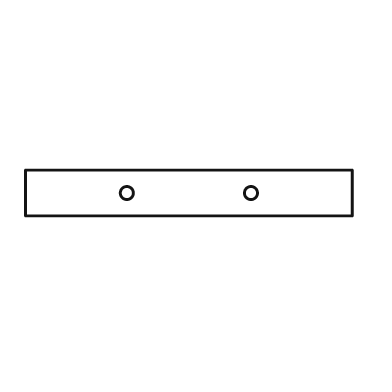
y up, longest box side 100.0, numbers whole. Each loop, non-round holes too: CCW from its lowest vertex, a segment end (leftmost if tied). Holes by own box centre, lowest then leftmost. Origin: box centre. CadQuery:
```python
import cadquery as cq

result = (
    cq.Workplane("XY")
    .moveTo(-50.0, -7.0)
    .lineTo(50.0, -7.0)
    .lineTo(50.0, 7.0)
    .lineTo(-50.0, 7.0)
    .close()
    .moveTo(-19.0, 0.0)
    .circle(2.0)
    .moveTo(19.0, 0.0)
    .circle(2.0)
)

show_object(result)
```